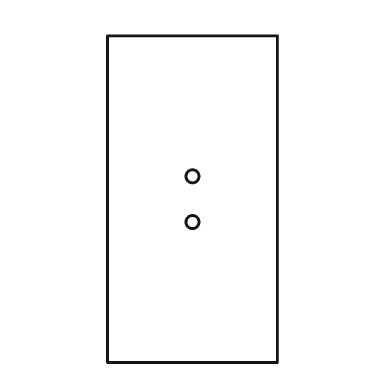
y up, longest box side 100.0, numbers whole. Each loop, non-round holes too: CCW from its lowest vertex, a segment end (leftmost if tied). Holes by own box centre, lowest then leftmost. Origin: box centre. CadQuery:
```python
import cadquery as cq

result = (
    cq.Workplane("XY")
    .moveTo(-26.0, -50.0)
    .lineTo(26.0, -50.0)
    .lineTo(26.0, 50.0)
    .lineTo(-26.0, 50.0)
    .close()
    .moveTo(0.0, -7.0)
    .circle(2.0)
    .moveTo(0.0, 7.0)
    .circle(2.0)
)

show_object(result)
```